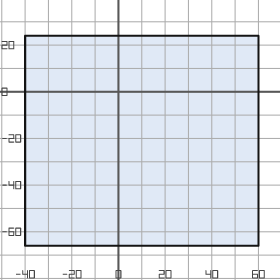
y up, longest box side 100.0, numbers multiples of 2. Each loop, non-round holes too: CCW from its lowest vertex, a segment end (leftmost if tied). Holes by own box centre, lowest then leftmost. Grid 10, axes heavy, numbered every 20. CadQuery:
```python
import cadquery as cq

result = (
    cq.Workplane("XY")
    .moveTo(-40.0, -66.0)
    .lineTo(60.0, -66.0)
    .lineTo(60.0, 24.0)
    .lineTo(-40.0, 24.0)
    .close()
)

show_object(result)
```